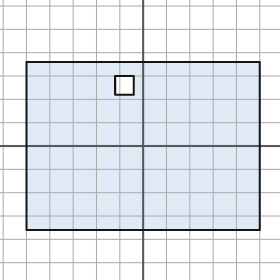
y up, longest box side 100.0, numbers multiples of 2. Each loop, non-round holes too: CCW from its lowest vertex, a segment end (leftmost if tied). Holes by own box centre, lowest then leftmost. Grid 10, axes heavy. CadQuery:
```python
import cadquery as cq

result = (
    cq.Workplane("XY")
    .moveTo(-50.0, -36.0)
    .lineTo(50.0, -36.0)
    .lineTo(50.0, 36.0)
    .lineTo(-50.0, 36.0)
    .close()
    .moveTo(-12.0, 22.0)
    .lineTo(-4.0, 22.0)
    .lineTo(-4.0, 30.0)
    .lineTo(-12.0, 30.0)
    .close()
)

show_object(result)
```